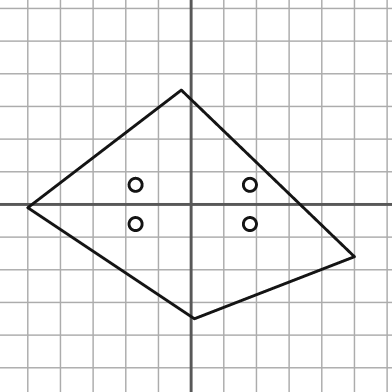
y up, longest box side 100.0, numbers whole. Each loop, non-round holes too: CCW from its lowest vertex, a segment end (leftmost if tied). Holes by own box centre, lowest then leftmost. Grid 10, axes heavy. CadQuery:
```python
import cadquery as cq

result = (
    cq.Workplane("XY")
    .moveTo(1.0, -35.0)
    .lineTo(50.0, -16.0)
    .lineTo(-3.0, 35.0)
    .lineTo(-50.0, -1.0)
    .close()
    .moveTo(-17.0, -6.0)
    .circle(2.0)
    .moveTo(18.0, -6.0)
    .circle(2.0)
    .moveTo(-17.0, 6.0)
    .circle(2.0)
    .moveTo(18.0, 6.0)
    .circle(2.0)
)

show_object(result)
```